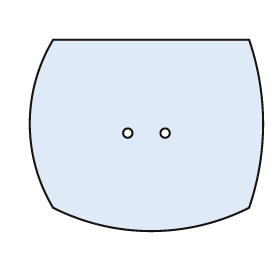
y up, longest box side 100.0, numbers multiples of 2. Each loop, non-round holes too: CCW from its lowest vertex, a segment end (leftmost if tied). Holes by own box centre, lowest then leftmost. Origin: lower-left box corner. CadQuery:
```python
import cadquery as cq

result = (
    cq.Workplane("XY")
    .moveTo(10.0, 10.0)
    .threePointArc((52.0, 0.0), (94.0, 10.0))
    .threePointArc((100.0, 46.0), (94.0, 82.0))
    .lineTo(10.0, 82.0)
    .threePointArc((0.0, 46.0), (10.0, 10.0))
    .close()
    .moveTo(42.0, 42.0)
    .circle(2.0)
    .moveTo(58.0, 42.0)
    .circle(2.0)
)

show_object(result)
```